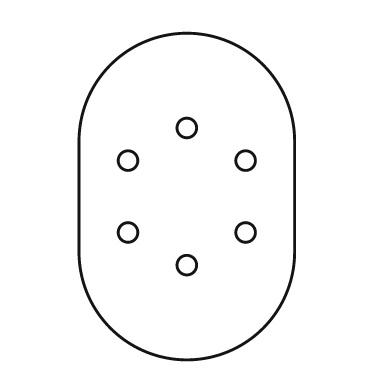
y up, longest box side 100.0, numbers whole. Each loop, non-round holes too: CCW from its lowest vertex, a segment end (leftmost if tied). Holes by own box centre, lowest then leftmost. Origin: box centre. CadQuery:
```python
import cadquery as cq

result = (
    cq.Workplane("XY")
    .moveTo(-33.0, -17.0)
    .threePointArc((0.0, -50.0), (33.0, -17.0))
    .lineTo(33.0, 17.0)
    .threePointArc((0.0, 50.0), (-33.0, 17.0))
    .close()
    .moveTo(0.0, -21.0)
    .circle(3.0)
    .moveTo(-18.0, -11.0)
    .circle(3.0)
    .moveTo(18.0, -11.0)
    .circle(3.0)
    .moveTo(-18.0, 11.0)
    .circle(3.0)
    .moveTo(18.0, 11.0)
    .circle(3.0)
    .moveTo(0.0, 21.0)
    .circle(3.0)
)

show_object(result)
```